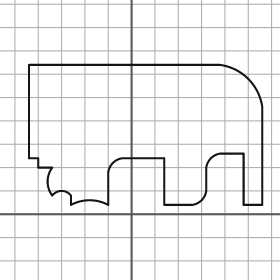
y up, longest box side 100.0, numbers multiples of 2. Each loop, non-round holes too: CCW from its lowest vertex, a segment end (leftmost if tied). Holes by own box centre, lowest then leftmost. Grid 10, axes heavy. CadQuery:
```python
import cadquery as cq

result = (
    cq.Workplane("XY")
    .moveTo(-26.0, 4.0)
    .threePointArc((-18.0, 6.0), (-10.0, 4.0))
    .lineTo(-10.0, 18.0)
    .threePointArc((-8.0, 22.0), (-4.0, 24.0))
    .lineTo(14.0, 24.0)
    .lineTo(14.0, 4.0)
    .lineTo(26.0, 4.0)
    .threePointArc((30.0, 6.0), (32.0, 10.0))
    .lineTo(32.0, 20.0)
    .threePointArc((34.0, 24.0), (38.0, 26.0))
    .lineTo(48.0, 26.0)
    .lineTo(48.0, 4.0)
    .lineTo(56.0, 4.0)
    .lineTo(56.0, 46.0)
    .threePointArc((50.0, 58.0), (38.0, 64.0))
    .lineTo(-44.0, 64.0)
    .lineTo(-44.0, 24.0)
    .lineTo(-40.0, 24.0)
    .lineTo(-40.0, 20.0)
    .lineTo(-34.0, 20.0)
    .threePointArc((-36.0, 14.0), (-34.0, 8.0))
    .threePointArc((-30.0, 10.0), (-26.0, 8.0))
    .close()
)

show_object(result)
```